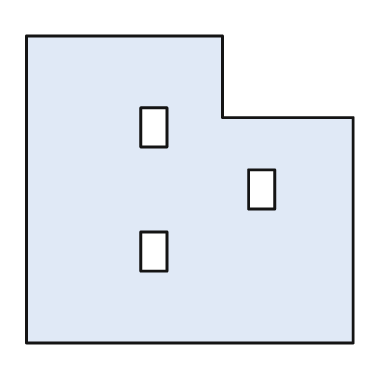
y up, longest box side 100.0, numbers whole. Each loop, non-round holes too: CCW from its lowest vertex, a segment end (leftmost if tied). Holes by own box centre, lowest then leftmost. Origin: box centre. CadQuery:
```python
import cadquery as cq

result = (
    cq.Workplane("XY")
    .moveTo(-50.0, -47.0)
    .lineTo(50.0, -47.0)
    .lineTo(50.0, 22.0)
    .lineTo(10.0, 22.0)
    .lineTo(10.0, 47.0)
    .lineTo(-50.0, 47.0)
    .close()
    .moveTo(-15.0, -25.0)
    .lineTo(-7.0, -25.0)
    .lineTo(-7.0, -13.0)
    .lineTo(-15.0, -13.0)
    .close()
    .moveTo(18.0, -6.0)
    .lineTo(26.0, -6.0)
    .lineTo(26.0, 6.0)
    .lineTo(18.0, 6.0)
    .close()
    .moveTo(-15.0, 13.0)
    .lineTo(-7.0, 13.0)
    .lineTo(-7.0, 25.0)
    .lineTo(-15.0, 25.0)
    .close()
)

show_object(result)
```